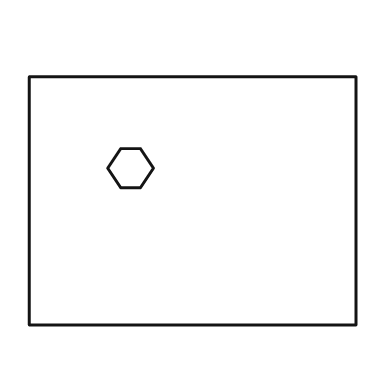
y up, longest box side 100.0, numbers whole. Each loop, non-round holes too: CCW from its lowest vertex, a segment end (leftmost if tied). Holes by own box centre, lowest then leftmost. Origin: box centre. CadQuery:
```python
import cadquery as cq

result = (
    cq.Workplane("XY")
    .moveTo(-50.0, -38.0)
    .lineTo(50.0, -38.0)
    .lineTo(50.0, 38.0)
    .lineTo(-50.0, 38.0)
    .close()
    .moveTo(-22.0, 4.0)
    .lineTo(-16.0, 4.0)
    .lineTo(-12.0, 10.0)
    .lineTo(-16.0, 16.0)
    .lineTo(-22.0, 16.0)
    .lineTo(-26.0, 10.0)
    .close()
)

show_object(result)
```